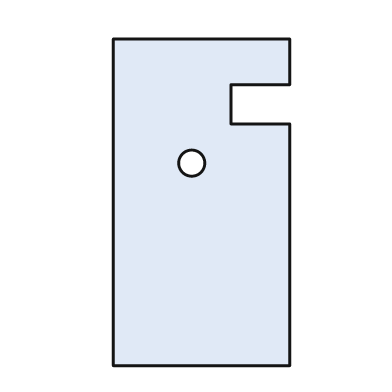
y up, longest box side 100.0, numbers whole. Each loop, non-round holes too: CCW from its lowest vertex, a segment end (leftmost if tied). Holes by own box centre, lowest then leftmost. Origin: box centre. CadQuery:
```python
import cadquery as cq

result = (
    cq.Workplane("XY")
    .moveTo(-27.0, -50.0)
    .lineTo(27.0, -50.0)
    .lineTo(27.0, 24.0)
    .lineTo(9.0, 24.0)
    .lineTo(9.0, 36.0)
    .lineTo(27.0, 36.0)
    .lineTo(27.0, 50.0)
    .lineTo(-27.0, 50.0)
    .close()
    .moveTo(-3.0, 12.0)
    .circle(4.0)
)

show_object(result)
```